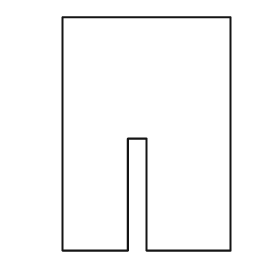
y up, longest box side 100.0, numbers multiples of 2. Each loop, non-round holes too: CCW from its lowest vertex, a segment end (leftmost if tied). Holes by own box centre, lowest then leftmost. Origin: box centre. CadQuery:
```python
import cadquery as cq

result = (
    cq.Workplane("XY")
    .moveTo(-36.0, -50.0)
    .lineTo(-8.0, -50.0)
    .lineTo(-8.0, -2.0)
    .lineTo(0.0, -2.0)
    .lineTo(0.0, -50.0)
    .lineTo(36.0, -50.0)
    .lineTo(36.0, 50.0)
    .lineTo(-36.0, 50.0)
    .close()
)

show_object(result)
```